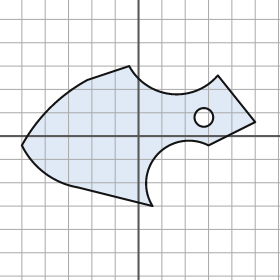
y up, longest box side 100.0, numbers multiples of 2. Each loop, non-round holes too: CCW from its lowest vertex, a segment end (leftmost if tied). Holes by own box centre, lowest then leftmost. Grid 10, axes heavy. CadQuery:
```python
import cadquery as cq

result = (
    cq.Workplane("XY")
    .moveTo(6.0, -30.0)
    .threePointArc((8.0, -8.0), (30.0, -4.0))
    .lineTo(50.0, 6.0)
    .lineTo(34.0, 26.0)
    .threePointArc((14.0, 18.0), (-4.0, 30.0))
    .lineTo(-22.0, 24.0)
    .threePointArc((-38.0, 12.0), (-50.0, -4.0))
    .threePointArc((-40.0, -16.0), (-26.0, -22.0))
    .close()
    .moveTo(28.0, 8.0)
    .circle(4.0)
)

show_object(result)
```